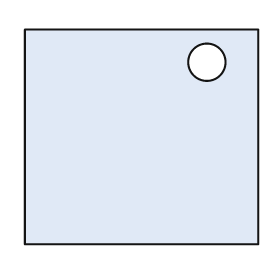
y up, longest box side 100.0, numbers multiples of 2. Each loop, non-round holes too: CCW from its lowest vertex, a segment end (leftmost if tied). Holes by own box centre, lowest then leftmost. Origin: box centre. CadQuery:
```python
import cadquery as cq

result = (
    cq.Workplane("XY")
    .moveTo(-50.0, -46.0)
    .lineTo(50.0, -46.0)
    .lineTo(50.0, 46.0)
    .lineTo(-50.0, 46.0)
    .close()
    .moveTo(28.0, 32.0)
    .circle(8.0)
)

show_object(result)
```